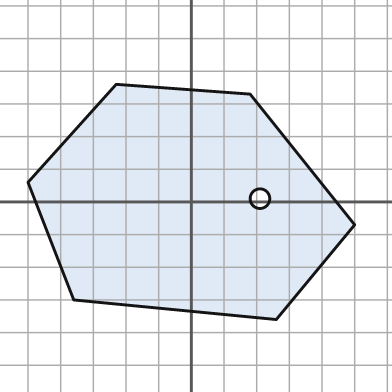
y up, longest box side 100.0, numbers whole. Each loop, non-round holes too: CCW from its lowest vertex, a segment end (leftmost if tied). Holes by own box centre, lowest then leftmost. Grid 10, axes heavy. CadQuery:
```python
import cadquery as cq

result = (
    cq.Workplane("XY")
    .moveTo(26.0, -36.0)
    .lineTo(50.0, -7.0)
    .lineTo(18.0, 33.0)
    .lineTo(-23.0, 36.0)
    .lineTo(-50.0, 6.0)
    .lineTo(-36.0, -30.0)
    .close()
    .moveTo(21.0, 1.0)
    .circle(3.0)
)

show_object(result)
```